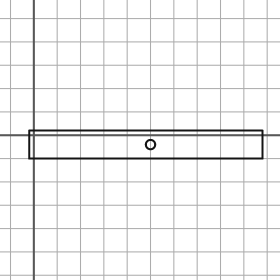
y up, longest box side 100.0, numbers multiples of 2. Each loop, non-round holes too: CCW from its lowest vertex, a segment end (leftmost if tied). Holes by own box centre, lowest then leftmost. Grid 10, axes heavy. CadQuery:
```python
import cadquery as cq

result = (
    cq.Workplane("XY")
    .moveTo(-2.0, -10.0)
    .lineTo(98.0, -10.0)
    .lineTo(98.0, 2.0)
    .lineTo(-2.0, 2.0)
    .close()
    .moveTo(50.0, -4.0)
    .circle(2.0)
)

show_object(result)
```